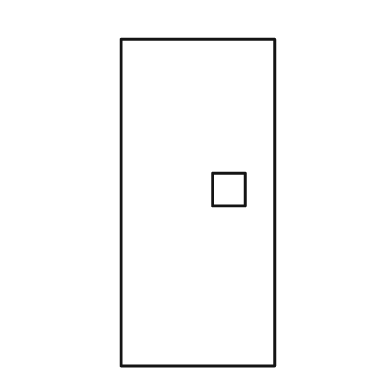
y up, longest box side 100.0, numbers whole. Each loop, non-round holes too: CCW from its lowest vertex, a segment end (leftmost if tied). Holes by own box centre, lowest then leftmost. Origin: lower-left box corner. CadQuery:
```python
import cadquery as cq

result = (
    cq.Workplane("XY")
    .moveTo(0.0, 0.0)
    .lineTo(47.0, 0.0)
    .lineTo(47.0, 100.0)
    .lineTo(0.0, 100.0)
    .close()
    .moveTo(28.0, 49.0)
    .lineTo(38.0, 49.0)
    .lineTo(38.0, 59.0)
    .lineTo(28.0, 59.0)
    .close()
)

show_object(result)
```